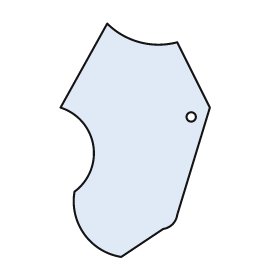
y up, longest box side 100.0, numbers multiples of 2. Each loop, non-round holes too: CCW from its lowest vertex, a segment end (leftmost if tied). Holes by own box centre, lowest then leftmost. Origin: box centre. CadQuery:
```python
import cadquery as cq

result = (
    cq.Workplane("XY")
    .moveTo(-6.0, -50.0)
    .lineTo(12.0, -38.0)
    .threePointArc((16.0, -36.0), (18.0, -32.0))
    .lineTo(32.0, 14.0)
    .lineTo(18.0, 42.0)
    .threePointArc((2.0, 42.0), (-12.0, 50.0))
    .lineTo(-32.0, 14.0)
    .threePointArc((-18.0, -2.0), (-26.0, -22.0))
    .threePointArc((-22.0, -40.0), (-6.0, -50.0))
    .close()
    .moveTo(24.0, 10.0)
    .circle(2.0)
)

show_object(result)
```